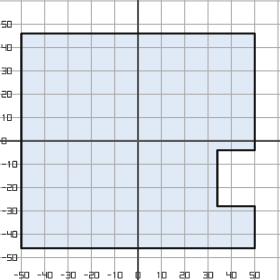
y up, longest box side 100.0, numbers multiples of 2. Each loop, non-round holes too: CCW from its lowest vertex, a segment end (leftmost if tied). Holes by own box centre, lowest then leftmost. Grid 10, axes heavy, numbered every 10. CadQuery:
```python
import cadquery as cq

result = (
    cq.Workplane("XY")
    .moveTo(-50.0, -46.0)
    .lineTo(50.0, -46.0)
    .lineTo(50.0, -28.0)
    .lineTo(34.0, -28.0)
    .lineTo(34.0, -4.0)
    .lineTo(50.0, -4.0)
    .lineTo(50.0, 46.0)
    .lineTo(-50.0, 46.0)
    .close()
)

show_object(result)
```